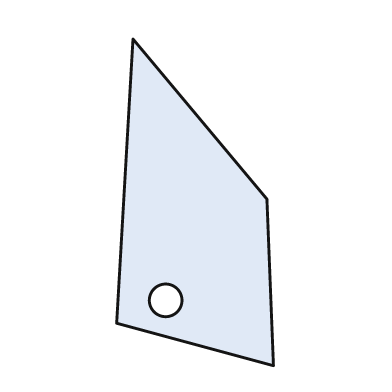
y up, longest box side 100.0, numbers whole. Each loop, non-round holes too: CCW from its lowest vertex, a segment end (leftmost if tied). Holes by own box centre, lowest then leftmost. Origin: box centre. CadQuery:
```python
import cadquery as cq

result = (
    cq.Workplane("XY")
    .moveTo(24.0, -50.0)
    .lineTo(22.0, 1.0)
    .lineTo(-19.0, 50.0)
    .lineTo(-24.0, -37.0)
    .close()
    .moveTo(-9.0, -30.0)
    .circle(5.0)
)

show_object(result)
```